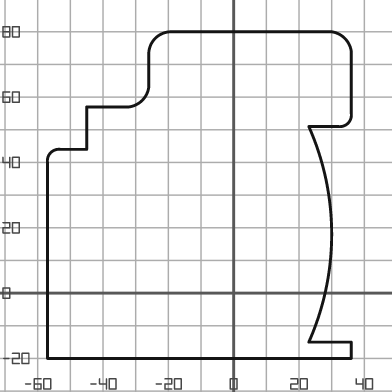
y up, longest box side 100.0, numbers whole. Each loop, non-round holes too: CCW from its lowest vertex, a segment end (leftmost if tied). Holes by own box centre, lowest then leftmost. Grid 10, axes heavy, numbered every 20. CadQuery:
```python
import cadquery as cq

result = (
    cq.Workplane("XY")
    .moveTo(-57.0, -20.0)
    .lineTo(36.0, -20.0)
    .lineTo(36.0, -15.0)
    .lineTo(23.0, -15.0)
    .threePointArc((30.0, 18.0), (23.0, 51.0))
    .lineTo(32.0, 51.0)
    .threePointArc((35.0, 52.0), (36.0, 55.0))
    .lineTo(36.0, 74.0)
    .threePointArc((34.0, 78.0), (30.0, 80.0))
    .lineTo(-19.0, 80.0)
    .threePointArc((-24.0, 78.0), (-26.0, 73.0))
    .lineTo(-26.0, 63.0)
    .threePointArc((-28.0, 59.0), (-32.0, 57.0))
    .lineTo(-45.0, 57.0)
    .lineTo(-45.0, 44.0)
    .lineTo(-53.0, 44.0)
    .threePointArc((-56.0, 43.0), (-57.0, 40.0))
    .close()
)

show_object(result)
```